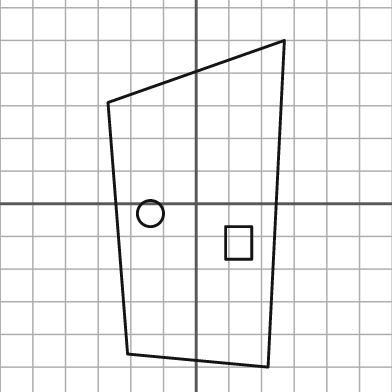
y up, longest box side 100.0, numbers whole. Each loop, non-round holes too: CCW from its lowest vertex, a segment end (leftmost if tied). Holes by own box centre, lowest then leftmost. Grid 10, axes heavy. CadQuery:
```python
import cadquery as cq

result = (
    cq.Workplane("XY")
    .moveTo(22.0, -50.0)
    .lineTo(27.0, 50.0)
    .lineTo(-27.0, 31.0)
    .lineTo(-21.0, -46.0)
    .close()
    .moveTo(9.0, -17.0)
    .lineTo(17.0, -17.0)
    .lineTo(17.0, -7.0)
    .lineTo(9.0, -7.0)
    .close()
    .moveTo(-14.0, -3.0)
    .circle(4.0)
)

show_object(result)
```